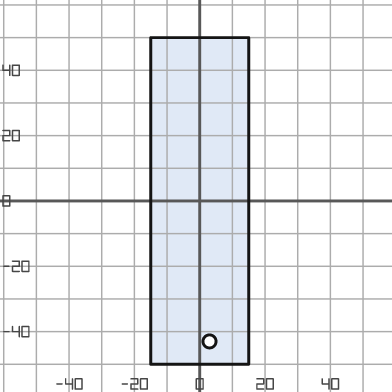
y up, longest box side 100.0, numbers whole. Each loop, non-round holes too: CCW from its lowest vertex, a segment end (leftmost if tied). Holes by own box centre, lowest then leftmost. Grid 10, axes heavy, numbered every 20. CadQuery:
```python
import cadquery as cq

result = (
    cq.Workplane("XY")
    .moveTo(-15.0, -50.0)
    .lineTo(15.0, -50.0)
    .lineTo(15.0, 50.0)
    .lineTo(-15.0, 50.0)
    .close()
    .moveTo(3.0, -43.0)
    .circle(2.0)
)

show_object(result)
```